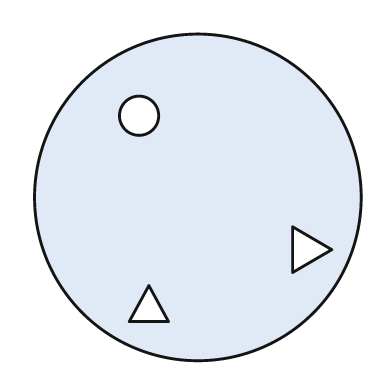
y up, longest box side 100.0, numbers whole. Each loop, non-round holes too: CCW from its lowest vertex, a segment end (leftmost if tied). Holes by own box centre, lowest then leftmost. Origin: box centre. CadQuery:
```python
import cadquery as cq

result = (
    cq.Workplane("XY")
    .moveTo(0.0, 0.0)
    .circle(50.0)
    .moveTo(-21.0, -38.0)
    .lineTo(-9.0, -38.0)
    .lineTo(-15.0, -27.0)
    .close()
    .moveTo(29.0, -23.0)
    .lineTo(41.0, -16.0)
    .lineTo(29.0, -9.0)
    .close()
    .moveTo(-18.0, 25.0)
    .circle(6.0)
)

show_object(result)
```